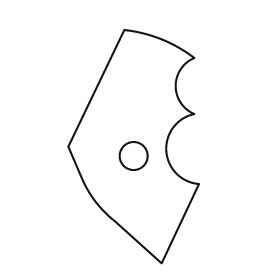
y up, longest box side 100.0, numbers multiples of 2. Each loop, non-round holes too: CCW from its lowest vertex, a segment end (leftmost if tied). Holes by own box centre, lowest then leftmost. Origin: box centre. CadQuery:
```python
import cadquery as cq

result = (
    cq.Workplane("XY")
    .moveTo(12.0, -50.0)
    .lineTo(28.0, -16.0)
    .threePointArc((14.0, -2.0), (26.0, 14.0))
    .threePointArc((18.0, 26.0), (26.0, 38.0))
    .threePointArc((12.0, 46.0), (-4.0, 50.0))
    .lineTo(-28.0, 0.0)
    .lineTo(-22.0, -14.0)
    .threePointArc((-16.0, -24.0), (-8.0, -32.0))
    .close()
    .moveTo(0.0, -4.0)
    .circle(6.0)
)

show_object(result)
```